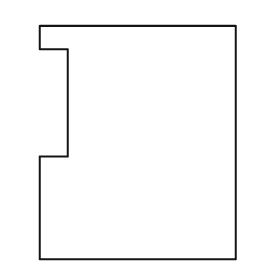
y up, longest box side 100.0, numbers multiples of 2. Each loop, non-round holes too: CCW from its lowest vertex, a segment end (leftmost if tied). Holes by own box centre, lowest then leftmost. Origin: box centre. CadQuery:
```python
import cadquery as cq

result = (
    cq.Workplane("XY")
    .moveTo(-42.0, -50.0)
    .lineTo(42.0, -50.0)
    .lineTo(42.0, 50.0)
    .lineTo(-42.0, 50.0)
    .lineTo(-42.0, 40.0)
    .lineTo(-30.0, 40.0)
    .lineTo(-30.0, -6.0)
    .lineTo(-42.0, -6.0)
    .close()
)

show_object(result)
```